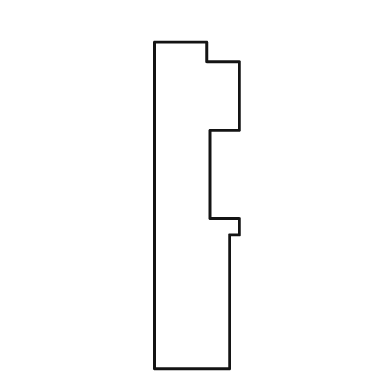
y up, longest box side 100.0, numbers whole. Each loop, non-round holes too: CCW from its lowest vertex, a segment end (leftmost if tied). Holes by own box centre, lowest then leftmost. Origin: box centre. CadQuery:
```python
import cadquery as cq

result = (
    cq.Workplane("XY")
    .moveTo(-13.0, -50.0)
    .lineTo(10.0, -50.0)
    .lineTo(10.0, -9.0)
    .lineTo(13.0, -9.0)
    .lineTo(13.0, -4.0)
    .lineTo(4.0, -4.0)
    .lineTo(4.0, 23.0)
    .lineTo(13.0, 23.0)
    .lineTo(13.0, 44.0)
    .lineTo(3.0, 44.0)
    .lineTo(3.0, 50.0)
    .lineTo(-13.0, 50.0)
    .close()
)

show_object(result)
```